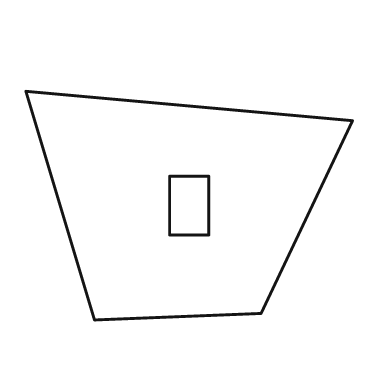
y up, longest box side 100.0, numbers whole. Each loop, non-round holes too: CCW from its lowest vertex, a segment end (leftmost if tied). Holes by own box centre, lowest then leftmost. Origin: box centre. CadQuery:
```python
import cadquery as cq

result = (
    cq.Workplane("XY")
    .moveTo(-29.0, -35.0)
    .lineTo(22.0, -33.0)
    .lineTo(50.0, 26.0)
    .lineTo(-50.0, 35.0)
    .close()
    .moveTo(-6.0, -9.0)
    .lineTo(6.0, -9.0)
    .lineTo(6.0, 9.0)
    .lineTo(-6.0, 9.0)
    .close()
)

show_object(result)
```